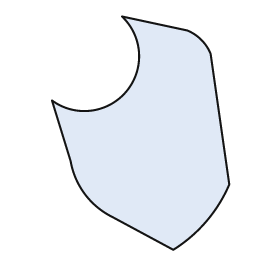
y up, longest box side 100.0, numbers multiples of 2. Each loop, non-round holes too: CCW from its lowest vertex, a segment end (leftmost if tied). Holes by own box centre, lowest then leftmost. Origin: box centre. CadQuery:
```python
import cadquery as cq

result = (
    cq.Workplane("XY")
    .moveTo(14.0, -50.0)
    .threePointArc((28.0, -38.0), (38.0, -22.0))
    .lineTo(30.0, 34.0)
    .threePointArc((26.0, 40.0), (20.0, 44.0))
    .lineTo(-8.0, 50.0)
    .threePointArc((-6.0, 18.0), (-38.0, 14.0))
    .lineTo(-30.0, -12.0)
    .threePointArc((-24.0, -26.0), (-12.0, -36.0))
    .close()
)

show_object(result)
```